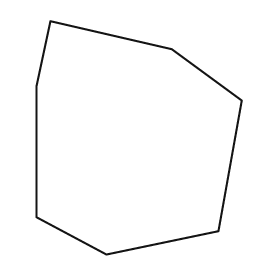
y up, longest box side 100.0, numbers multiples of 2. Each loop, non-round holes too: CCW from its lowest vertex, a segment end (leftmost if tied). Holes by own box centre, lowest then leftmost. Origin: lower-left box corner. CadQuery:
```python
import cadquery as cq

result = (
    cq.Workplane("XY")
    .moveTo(30.0, 0.0)
    .lineTo(78.0, 10.0)
    .lineTo(88.0, 66.0)
    .lineTo(58.0, 88.0)
    .lineTo(6.0, 100.0)
    .lineTo(0.0, 72.0)
    .lineTo(0.0, 16.0)
    .close()
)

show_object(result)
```